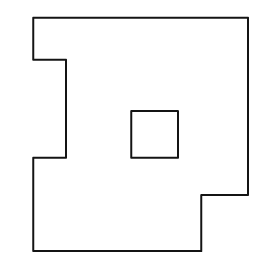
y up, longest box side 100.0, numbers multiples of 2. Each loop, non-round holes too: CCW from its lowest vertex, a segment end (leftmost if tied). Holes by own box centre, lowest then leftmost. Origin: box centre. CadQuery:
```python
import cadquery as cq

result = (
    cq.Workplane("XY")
    .moveTo(-46.0, -50.0)
    .lineTo(26.0, -50.0)
    .lineTo(26.0, -26.0)
    .lineTo(46.0, -26.0)
    .lineTo(46.0, 50.0)
    .lineTo(-46.0, 50.0)
    .lineTo(-46.0, 32.0)
    .lineTo(-32.0, 32.0)
    .lineTo(-32.0, -10.0)
    .lineTo(-46.0, -10.0)
    .close()
    .moveTo(-4.0, -10.0)
    .lineTo(16.0, -10.0)
    .lineTo(16.0, 10.0)
    .lineTo(-4.0, 10.0)
    .close()
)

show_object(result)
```